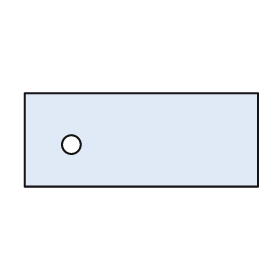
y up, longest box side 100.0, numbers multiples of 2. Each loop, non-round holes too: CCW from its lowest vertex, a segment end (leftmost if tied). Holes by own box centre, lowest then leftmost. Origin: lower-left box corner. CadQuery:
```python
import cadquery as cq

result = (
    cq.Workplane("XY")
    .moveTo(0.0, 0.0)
    .lineTo(100.0, 0.0)
    .lineTo(100.0, 40.0)
    .lineTo(0.0, 40.0)
    .close()
    .moveTo(20.0, 18.0)
    .circle(4.0)
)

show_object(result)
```